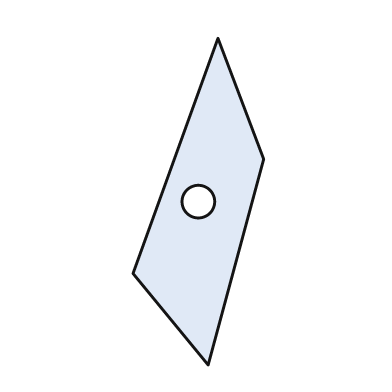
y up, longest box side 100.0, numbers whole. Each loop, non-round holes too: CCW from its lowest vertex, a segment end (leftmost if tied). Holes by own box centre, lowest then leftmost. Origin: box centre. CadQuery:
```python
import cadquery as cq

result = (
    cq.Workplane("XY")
    .moveTo(3.0, -50.0)
    .lineTo(20.0, 13.0)
    .lineTo(6.0, 50.0)
    .lineTo(-20.0, -22.0)
    .close()
    .moveTo(0.0, 0.0)
    .circle(5.0)
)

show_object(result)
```